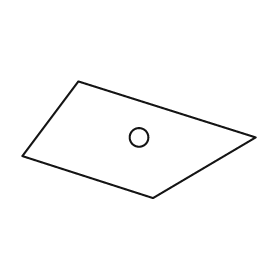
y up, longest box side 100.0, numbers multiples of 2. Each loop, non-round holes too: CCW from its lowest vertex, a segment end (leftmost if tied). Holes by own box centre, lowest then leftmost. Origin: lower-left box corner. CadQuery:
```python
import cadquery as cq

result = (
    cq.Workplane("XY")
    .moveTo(56.0, 0.0)
    .lineTo(100.0, 26.0)
    .lineTo(24.0, 50.0)
    .lineTo(0.0, 18.0)
    .close()
    .moveTo(50.0, 26.0)
    .circle(4.0)
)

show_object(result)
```